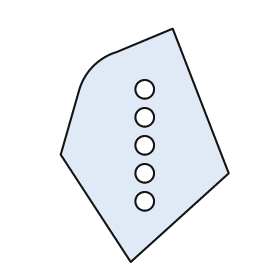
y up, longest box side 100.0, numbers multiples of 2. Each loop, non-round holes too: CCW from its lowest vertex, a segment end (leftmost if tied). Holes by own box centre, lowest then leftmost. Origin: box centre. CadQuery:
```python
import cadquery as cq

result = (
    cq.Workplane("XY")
    .moveTo(-6.0, -50.0)
    .lineTo(36.0, -12.0)
    .lineTo(12.0, 50.0)
    .lineTo(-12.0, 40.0)
    .threePointArc((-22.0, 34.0), (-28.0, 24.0))
    .lineTo(-36.0, -4.0)
    .close()
    .moveTo(0.0, -24.0)
    .circle(4.0)
    .moveTo(0.0, -12.0)
    .circle(4.0)
    .moveTo(0.0, 0.0)
    .circle(4.0)
    .moveTo(0.0, 12.0)
    .circle(4.0)
    .moveTo(0.0, 24.0)
    .circle(4.0)
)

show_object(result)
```